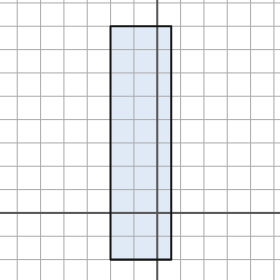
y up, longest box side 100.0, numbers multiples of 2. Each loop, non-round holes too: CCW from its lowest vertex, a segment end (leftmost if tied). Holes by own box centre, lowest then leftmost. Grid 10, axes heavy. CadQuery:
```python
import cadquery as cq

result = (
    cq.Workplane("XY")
    .moveTo(-20.0, -20.0)
    .lineTo(6.0, -20.0)
    .lineTo(6.0, 80.0)
    .lineTo(-20.0, 80.0)
    .close()
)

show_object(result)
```